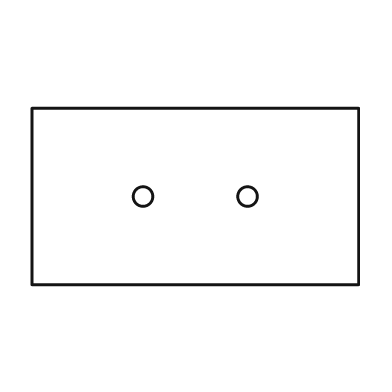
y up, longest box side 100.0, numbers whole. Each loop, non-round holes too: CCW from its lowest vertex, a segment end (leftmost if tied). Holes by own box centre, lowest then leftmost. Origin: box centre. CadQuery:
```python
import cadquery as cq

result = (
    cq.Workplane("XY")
    .moveTo(-50.0, -27.0)
    .lineTo(50.0, -27.0)
    .lineTo(50.0, 27.0)
    .lineTo(-50.0, 27.0)
    .close()
    .moveTo(-16.0, 0.0)
    .circle(3.0)
    .moveTo(16.0, 0.0)
    .circle(3.0)
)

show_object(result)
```